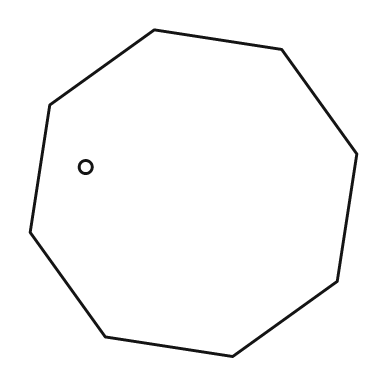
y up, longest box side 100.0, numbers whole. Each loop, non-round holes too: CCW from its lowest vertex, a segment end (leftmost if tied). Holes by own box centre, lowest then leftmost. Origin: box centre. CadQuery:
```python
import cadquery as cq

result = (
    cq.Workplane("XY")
    .moveTo(12.0, -50.0)
    .lineTo(44.0, -27.0)
    .lineTo(50.0, 12.0)
    .lineTo(27.0, 44.0)
    .lineTo(-12.0, 50.0)
    .lineTo(-44.0, 27.0)
    .lineTo(-50.0, -12.0)
    .lineTo(-27.0, -44.0)
    .close()
    .moveTo(-33.0, 8.0)
    .circle(2.0)
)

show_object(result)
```